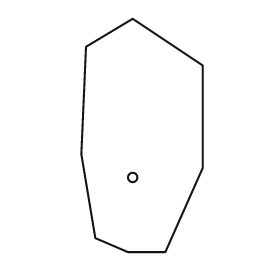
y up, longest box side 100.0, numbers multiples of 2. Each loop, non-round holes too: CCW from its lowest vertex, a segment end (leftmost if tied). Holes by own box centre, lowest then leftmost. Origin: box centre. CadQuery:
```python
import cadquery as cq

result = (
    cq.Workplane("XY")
    .moveTo(-6.0, -50.0)
    .lineTo(10.0, -50.0)
    .lineTo(26.0, -14.0)
    .lineTo(26.0, 30.0)
    .lineTo(-4.0, 50.0)
    .lineTo(-24.0, 38.0)
    .lineTo(-26.0, -8.0)
    .lineTo(-20.0, -44.0)
    .close()
    .moveTo(-4.0, -18.0)
    .circle(2.0)
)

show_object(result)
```